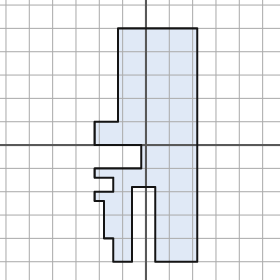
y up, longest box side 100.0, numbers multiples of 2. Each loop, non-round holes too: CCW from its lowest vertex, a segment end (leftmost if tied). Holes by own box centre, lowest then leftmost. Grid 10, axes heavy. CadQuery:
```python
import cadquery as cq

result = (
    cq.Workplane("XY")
    .moveTo(-14.0, -50.0)
    .lineTo(-6.0, -50.0)
    .lineTo(-6.0, -18.0)
    .lineTo(4.0, -18.0)
    .lineTo(4.0, -50.0)
    .lineTo(22.0, -50.0)
    .lineTo(22.0, 50.0)
    .lineTo(-12.0, 50.0)
    .lineTo(-12.0, 10.0)
    .lineTo(-22.0, 10.0)
    .lineTo(-22.0, 0.0)
    .lineTo(-2.0, 0.0)
    .lineTo(-2.0, -10.0)
    .lineTo(-22.0, -10.0)
    .lineTo(-22.0, -14.0)
    .lineTo(-14.0, -14.0)
    .lineTo(-14.0, -20.0)
    .lineTo(-22.0, -20.0)
    .lineTo(-22.0, -24.0)
    .lineTo(-18.0, -24.0)
    .lineTo(-18.0, -40.0)
    .lineTo(-14.0, -40.0)
    .close()
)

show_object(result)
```